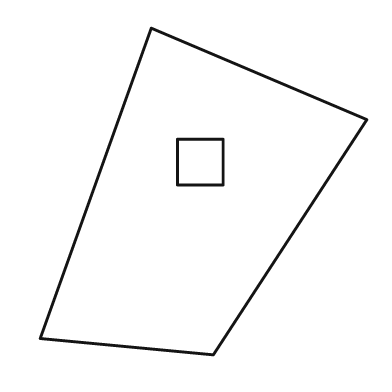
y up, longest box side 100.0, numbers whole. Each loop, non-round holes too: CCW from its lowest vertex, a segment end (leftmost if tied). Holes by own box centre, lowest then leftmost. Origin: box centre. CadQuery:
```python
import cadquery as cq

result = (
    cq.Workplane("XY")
    .moveTo(3.0, -50.0)
    .lineTo(50.0, 22.0)
    .lineTo(-16.0, 50.0)
    .lineTo(-50.0, -45.0)
    .close()
    .moveTo(-8.0, 2.0)
    .lineTo(6.0, 2.0)
    .lineTo(6.0, 16.0)
    .lineTo(-8.0, 16.0)
    .close()
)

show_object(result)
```